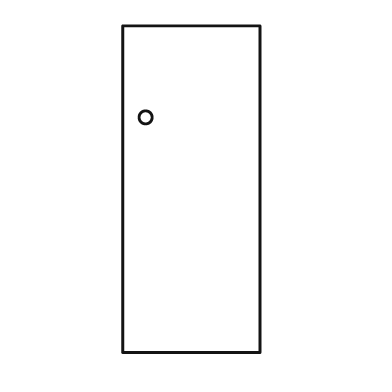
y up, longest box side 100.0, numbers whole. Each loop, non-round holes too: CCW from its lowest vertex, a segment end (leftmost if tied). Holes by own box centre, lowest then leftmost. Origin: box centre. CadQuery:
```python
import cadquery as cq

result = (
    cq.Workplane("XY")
    .moveTo(-21.0, -50.0)
    .lineTo(21.0, -50.0)
    .lineTo(21.0, 50.0)
    .lineTo(-21.0, 50.0)
    .close()
    .moveTo(-14.0, 22.0)
    .circle(2.0)
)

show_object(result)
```